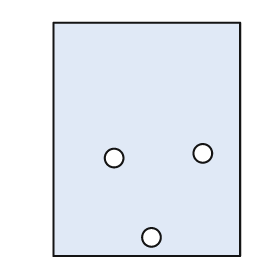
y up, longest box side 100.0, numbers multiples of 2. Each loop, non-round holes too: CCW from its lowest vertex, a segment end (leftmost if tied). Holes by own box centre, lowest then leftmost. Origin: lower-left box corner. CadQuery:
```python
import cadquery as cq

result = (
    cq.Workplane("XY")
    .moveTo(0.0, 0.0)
    .lineTo(80.0, 0.0)
    .lineTo(80.0, 100.0)
    .lineTo(0.0, 100.0)
    .close()
    .moveTo(42.0, 8.0)
    .circle(4.0)
    .moveTo(26.0, 42.0)
    .circle(4.0)
    .moveTo(64.0, 44.0)
    .circle(4.0)
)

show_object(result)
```